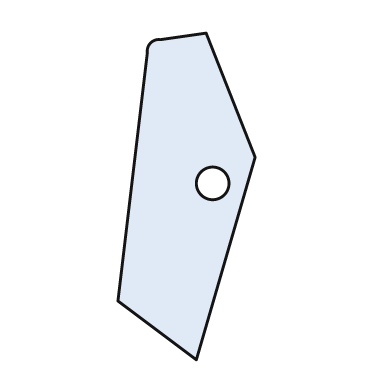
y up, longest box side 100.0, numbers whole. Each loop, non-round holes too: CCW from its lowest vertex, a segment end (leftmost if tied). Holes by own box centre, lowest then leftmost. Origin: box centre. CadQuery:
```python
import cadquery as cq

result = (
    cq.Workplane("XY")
    .moveTo(3.0, -50.0)
    .lineTo(21.0, 12.0)
    .lineTo(6.0, 50.0)
    .lineTo(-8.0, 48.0)
    .threePointArc((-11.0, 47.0), (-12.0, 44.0))
    .lineTo(-21.0, -32.0)
    .close()
    .moveTo(8.0, 4.0)
    .circle(5.0)
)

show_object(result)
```